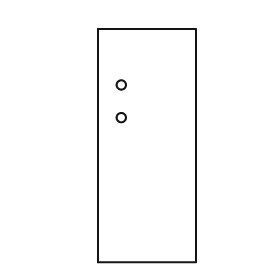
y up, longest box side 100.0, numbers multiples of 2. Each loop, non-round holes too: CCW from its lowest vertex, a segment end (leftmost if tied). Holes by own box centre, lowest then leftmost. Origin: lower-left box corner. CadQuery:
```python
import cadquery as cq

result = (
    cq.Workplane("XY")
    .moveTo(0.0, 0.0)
    .lineTo(42.0, 0.0)
    .lineTo(42.0, 100.0)
    .lineTo(0.0, 100.0)
    .close()
    .moveTo(10.0, 62.0)
    .circle(2.0)
    .moveTo(10.0, 76.0)
    .circle(2.0)
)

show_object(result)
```